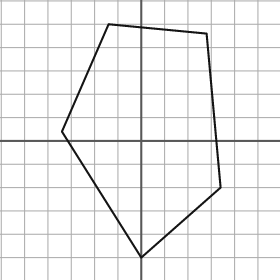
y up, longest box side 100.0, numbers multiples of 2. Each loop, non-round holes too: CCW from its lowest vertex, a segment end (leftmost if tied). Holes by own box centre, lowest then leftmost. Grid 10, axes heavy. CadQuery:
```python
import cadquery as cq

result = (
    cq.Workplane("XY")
    .moveTo(0.0, -50.0)
    .lineTo(34.0, -20.0)
    .lineTo(28.0, 46.0)
    .lineTo(-14.0, 50.0)
    .lineTo(-34.0, 4.0)
    .close()
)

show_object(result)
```